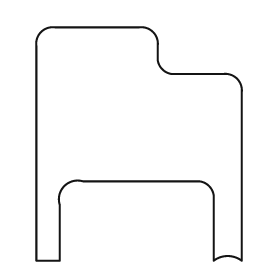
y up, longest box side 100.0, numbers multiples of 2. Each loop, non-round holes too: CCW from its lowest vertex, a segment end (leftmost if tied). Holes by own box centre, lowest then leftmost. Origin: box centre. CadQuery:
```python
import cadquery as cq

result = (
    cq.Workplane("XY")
    .moveTo(-44.0, -50.0)
    .lineTo(-34.0, -50.0)
    .lineTo(-34.0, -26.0)
    .threePointArc((-32.0, -18.0), (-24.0, -16.0))
    .lineTo(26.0, -16.0)
    .threePointArc((30.0, -18.0), (32.0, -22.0))
    .lineTo(32.0, -50.0)
    .threePointArc((38.0, -48.0), (44.0, -50.0))
    .lineTo(44.0, 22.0)
    .threePointArc((42.0, 28.0), (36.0, 30.0))
    .lineTo(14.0, 30.0)
    .threePointArc((10.0, 32.0), (8.0, 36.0))
    .lineTo(8.0, 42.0)
    .threePointArc((6.0, 48.0), (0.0, 50.0))
    .lineTo(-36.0, 50.0)
    .threePointArc((-42.0, 48.0), (-44.0, 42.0))
    .close()
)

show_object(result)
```